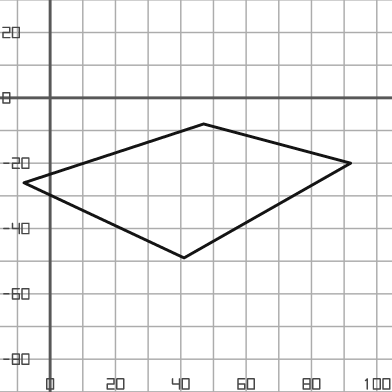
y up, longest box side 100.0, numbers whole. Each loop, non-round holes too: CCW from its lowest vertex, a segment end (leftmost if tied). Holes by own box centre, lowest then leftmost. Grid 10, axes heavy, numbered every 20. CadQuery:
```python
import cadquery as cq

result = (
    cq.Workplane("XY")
    .moveTo(41.0, -49.0)
    .lineTo(92.0, -20.0)
    .lineTo(47.0, -8.0)
    .lineTo(-8.0, -26.0)
    .close()
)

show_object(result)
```